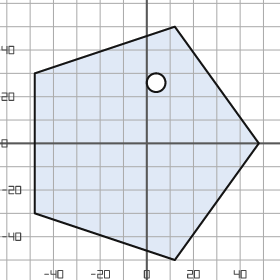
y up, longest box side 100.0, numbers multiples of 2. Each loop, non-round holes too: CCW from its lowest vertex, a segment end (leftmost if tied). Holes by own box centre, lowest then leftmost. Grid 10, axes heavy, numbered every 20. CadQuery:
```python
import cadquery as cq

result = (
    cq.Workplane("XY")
    .moveTo(12.0, -50.0)
    .lineTo(48.0, 0.0)
    .lineTo(12.0, 50.0)
    .lineTo(-48.0, 30.0)
    .lineTo(-48.0, -30.0)
    .close()
    .moveTo(4.0, 26.0)
    .circle(4.0)
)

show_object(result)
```